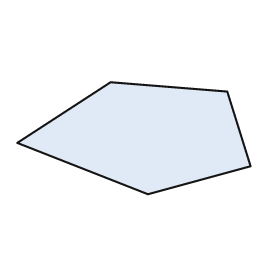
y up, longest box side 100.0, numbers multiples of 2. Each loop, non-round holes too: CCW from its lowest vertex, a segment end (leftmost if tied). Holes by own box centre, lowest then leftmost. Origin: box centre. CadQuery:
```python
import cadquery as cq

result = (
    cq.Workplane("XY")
    .moveTo(6.0, -24.0)
    .lineTo(50.0, -12.0)
    .lineTo(40.0, 20.0)
    .lineTo(-10.0, 24.0)
    .lineTo(-50.0, -2.0)
    .close()
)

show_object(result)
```